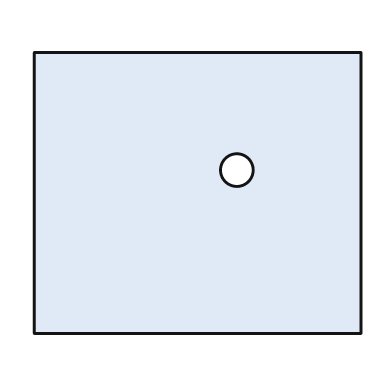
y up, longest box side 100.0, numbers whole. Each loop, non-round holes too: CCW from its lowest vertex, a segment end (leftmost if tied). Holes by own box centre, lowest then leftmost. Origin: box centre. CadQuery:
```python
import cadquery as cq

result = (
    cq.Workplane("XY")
    .moveTo(-50.0, -43.0)
    .lineTo(50.0, -43.0)
    .lineTo(50.0, 43.0)
    .lineTo(-50.0, 43.0)
    .close()
    .moveTo(12.0, 7.0)
    .circle(5.0)
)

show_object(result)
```